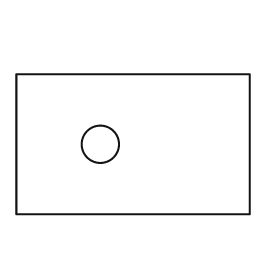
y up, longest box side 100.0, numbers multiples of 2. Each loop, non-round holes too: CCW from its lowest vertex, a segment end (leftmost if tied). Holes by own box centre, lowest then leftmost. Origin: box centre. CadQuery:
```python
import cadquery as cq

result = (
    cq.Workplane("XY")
    .moveTo(-50.0, -30.0)
    .lineTo(50.0, -30.0)
    .lineTo(50.0, 30.0)
    .lineTo(-50.0, 30.0)
    .close()
    .moveTo(-14.0, 0.0)
    .circle(8.0)
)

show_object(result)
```